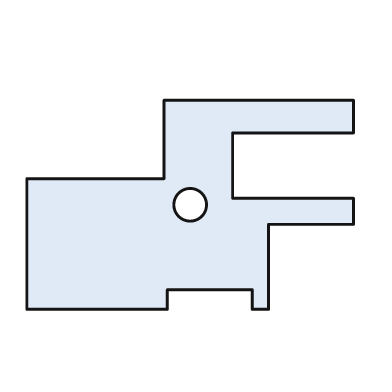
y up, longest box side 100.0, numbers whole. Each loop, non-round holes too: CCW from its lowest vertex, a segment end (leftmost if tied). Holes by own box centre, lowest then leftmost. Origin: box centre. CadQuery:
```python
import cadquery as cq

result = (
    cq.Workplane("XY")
    .moveTo(-50.0, -32.0)
    .lineTo(-7.0, -32.0)
    .lineTo(-7.0, -26.0)
    .lineTo(19.0, -26.0)
    .lineTo(19.0, -32.0)
    .lineTo(24.0, -32.0)
    .lineTo(24.0, -6.0)
    .lineTo(50.0, -6.0)
    .lineTo(50.0, 2.0)
    .lineTo(13.0, 2.0)
    .lineTo(13.0, 22.0)
    .lineTo(50.0, 22.0)
    .lineTo(50.0, 32.0)
    .lineTo(-8.0, 32.0)
    .lineTo(-8.0, 8.0)
    .lineTo(-50.0, 8.0)
    .close()
    .moveTo(0.0, 0.0)
    .circle(5.0)
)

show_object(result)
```